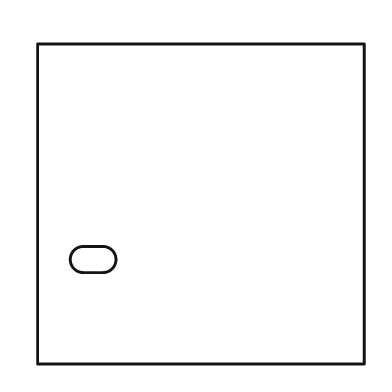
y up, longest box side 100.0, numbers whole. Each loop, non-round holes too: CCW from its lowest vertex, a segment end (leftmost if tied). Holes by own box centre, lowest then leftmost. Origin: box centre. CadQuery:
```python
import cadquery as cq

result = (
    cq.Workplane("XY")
    .moveTo(-50.0, -49.0)
    .lineTo(50.0, -49.0)
    .lineTo(50.0, 49.0)
    .lineTo(-50.0, 49.0)
    .close()
    .moveTo(-36.0, -21.0)
    .lineTo(-30.0, -21.0)
    .threePointArc((-26.0, -17.0), (-30.0, -13.0))
    .lineTo(-36.0, -13.0)
    .threePointArc((-40.0, -17.0), (-36.0, -21.0))
    .close()
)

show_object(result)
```